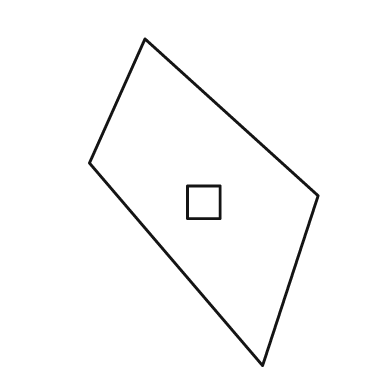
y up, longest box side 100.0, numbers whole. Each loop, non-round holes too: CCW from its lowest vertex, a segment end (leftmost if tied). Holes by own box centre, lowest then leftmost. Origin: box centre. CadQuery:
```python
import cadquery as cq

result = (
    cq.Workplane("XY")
    .moveTo(18.0, -50.0)
    .lineTo(35.0, 2.0)
    .lineTo(-18.0, 50.0)
    .lineTo(-35.0, 12.0)
    .close()
    .moveTo(-5.0, -5.0)
    .lineTo(5.0, -5.0)
    .lineTo(5.0, 5.0)
    .lineTo(-5.0, 5.0)
    .close()
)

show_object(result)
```